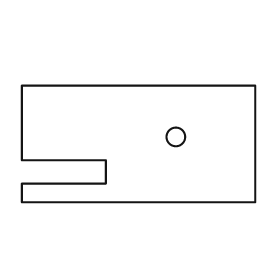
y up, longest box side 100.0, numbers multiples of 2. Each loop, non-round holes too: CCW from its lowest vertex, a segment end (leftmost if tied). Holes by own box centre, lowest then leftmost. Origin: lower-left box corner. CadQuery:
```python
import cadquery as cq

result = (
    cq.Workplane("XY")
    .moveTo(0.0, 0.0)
    .lineTo(100.0, 0.0)
    .lineTo(100.0, 50.0)
    .lineTo(0.0, 50.0)
    .lineTo(0.0, 18.0)
    .lineTo(36.0, 18.0)
    .lineTo(36.0, 8.0)
    .lineTo(0.0, 8.0)
    .close()
    .moveTo(66.0, 28.0)
    .circle(4.0)
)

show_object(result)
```